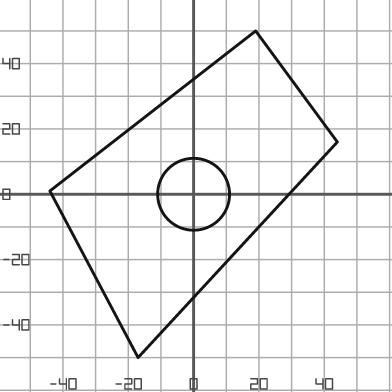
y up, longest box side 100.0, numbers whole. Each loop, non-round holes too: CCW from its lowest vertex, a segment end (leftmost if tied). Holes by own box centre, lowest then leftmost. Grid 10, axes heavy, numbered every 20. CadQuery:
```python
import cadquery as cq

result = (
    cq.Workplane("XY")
    .moveTo(-17.0, -50.0)
    .lineTo(44.0, 16.0)
    .lineTo(19.0, 50.0)
    .lineTo(-44.0, 1.0)
    .close()
    .moveTo(0.0, 0.0)
    .circle(11.0)
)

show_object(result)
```